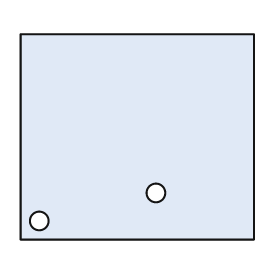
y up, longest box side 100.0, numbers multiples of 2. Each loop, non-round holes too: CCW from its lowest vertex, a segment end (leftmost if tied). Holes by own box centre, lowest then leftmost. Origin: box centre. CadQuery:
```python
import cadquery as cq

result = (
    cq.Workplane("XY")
    .moveTo(-50.0, -44.0)
    .lineTo(50.0, -44.0)
    .lineTo(50.0, 44.0)
    .lineTo(-50.0, 44.0)
    .close()
    .moveTo(-42.0, -36.0)
    .circle(4.0)
    .moveTo(8.0, -24.0)
    .circle(4.0)
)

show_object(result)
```